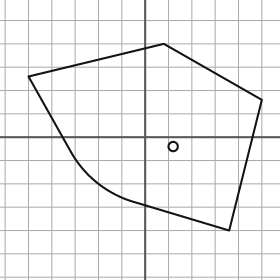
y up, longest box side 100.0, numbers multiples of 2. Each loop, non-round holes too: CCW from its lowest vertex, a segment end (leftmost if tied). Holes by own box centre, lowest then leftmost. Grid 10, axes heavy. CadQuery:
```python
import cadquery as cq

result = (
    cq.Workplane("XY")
    .moveTo(36.0, -40.0)
    .lineTo(50.0, 16.0)
    .lineTo(8.0, 40.0)
    .lineTo(-50.0, 26.0)
    .lineTo(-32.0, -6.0)
    .threePointArc((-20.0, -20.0), (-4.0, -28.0))
    .close()
    .moveTo(12.0, -4.0)
    .circle(2.0)
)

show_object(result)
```